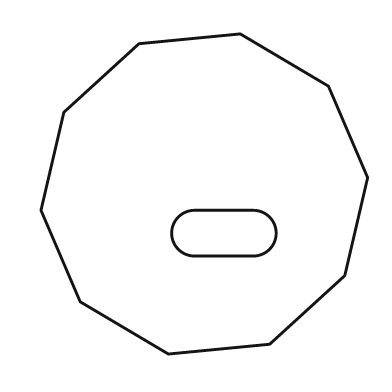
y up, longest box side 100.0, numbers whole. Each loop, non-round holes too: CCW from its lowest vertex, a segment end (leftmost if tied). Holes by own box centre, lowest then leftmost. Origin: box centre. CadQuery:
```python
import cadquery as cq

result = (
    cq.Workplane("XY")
    .moveTo(-11.0, -49.0)
    .lineTo(20.0, -46.0)
    .lineTo(43.0, -25.0)
    .lineTo(50.0, 5.0)
    .lineTo(38.0, 33.0)
    .lineTo(11.0, 49.0)
    .lineTo(-20.0, 46.0)
    .lineTo(-43.0, 25.0)
    .lineTo(-50.0, -5.0)
    .lineTo(-38.0, -33.0)
    .close()
    .moveTo(-3.0, -19.0)
    .lineTo(15.0, -19.0)
    .threePointArc((22.0, -12.0), (15.0, -5.0))
    .lineTo(-3.0, -5.0)
    .threePointArc((-10.0, -12.0), (-3.0, -19.0))
    .close()
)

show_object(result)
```